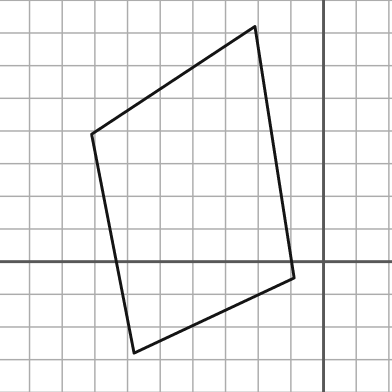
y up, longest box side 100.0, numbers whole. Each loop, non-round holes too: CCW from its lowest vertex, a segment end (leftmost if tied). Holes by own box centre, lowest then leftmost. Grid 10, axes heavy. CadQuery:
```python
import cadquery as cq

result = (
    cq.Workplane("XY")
    .moveTo(-58.0, -28.0)
    .lineTo(-9.0, -5.0)
    .lineTo(-21.0, 72.0)
    .lineTo(-71.0, 39.0)
    .close()
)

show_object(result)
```